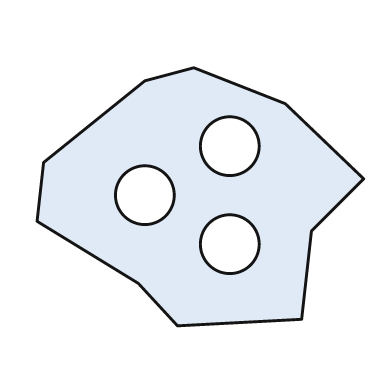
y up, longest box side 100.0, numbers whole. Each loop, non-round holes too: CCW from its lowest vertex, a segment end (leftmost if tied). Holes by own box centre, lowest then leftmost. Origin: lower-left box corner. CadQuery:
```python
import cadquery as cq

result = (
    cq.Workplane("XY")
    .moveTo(43.0, 0.0)
    .lineTo(81.0, 2.0)
    .lineTo(84.0, 29.0)
    .lineTo(100.0, 45.0)
    .lineTo(76.0, 68.0)
    .lineTo(48.0, 79.0)
    .lineTo(33.0, 75.0)
    .lineTo(2.0, 50.0)
    .lineTo(0.0, 32.0)
    .lineTo(31.0, 13.0)
    .close()
    .moveTo(59.0, 25.0)
    .circle(9.0)
    .moveTo(33.0, 40.0)
    .circle(9.0)
    .moveTo(59.0, 55.0)
    .circle(9.0)
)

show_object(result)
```